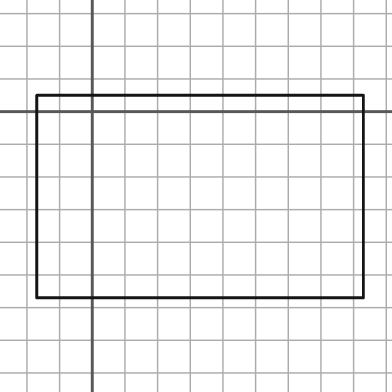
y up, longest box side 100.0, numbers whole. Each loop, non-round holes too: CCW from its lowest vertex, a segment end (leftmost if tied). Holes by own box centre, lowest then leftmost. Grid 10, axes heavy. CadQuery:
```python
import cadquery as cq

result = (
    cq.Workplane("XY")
    .moveTo(-17.0, -57.0)
    .lineTo(83.0, -57.0)
    .lineTo(83.0, 5.0)
    .lineTo(-17.0, 5.0)
    .close()
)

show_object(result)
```